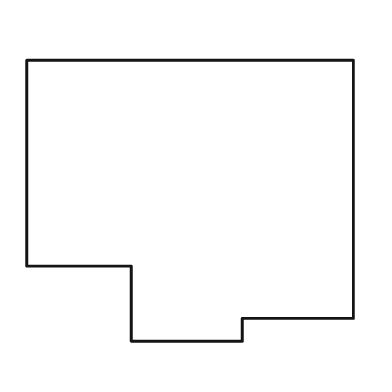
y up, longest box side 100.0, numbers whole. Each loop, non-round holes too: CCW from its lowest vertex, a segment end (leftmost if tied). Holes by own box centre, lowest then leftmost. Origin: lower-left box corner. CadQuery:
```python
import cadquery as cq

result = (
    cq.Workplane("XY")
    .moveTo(32.0, 0.0)
    .lineTo(66.0, 0.0)
    .lineTo(66.0, 7.0)
    .lineTo(100.0, 7.0)
    .lineTo(100.0, 86.0)
    .lineTo(0.0, 86.0)
    .lineTo(0.0, 23.0)
    .lineTo(32.0, 23.0)
    .close()
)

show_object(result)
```